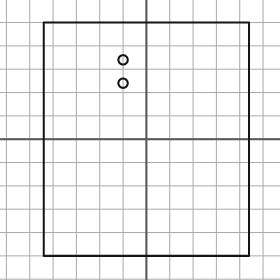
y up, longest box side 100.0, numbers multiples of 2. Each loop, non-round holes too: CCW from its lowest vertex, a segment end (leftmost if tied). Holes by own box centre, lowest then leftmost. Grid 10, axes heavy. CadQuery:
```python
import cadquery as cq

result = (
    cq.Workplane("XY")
    .moveTo(-44.0, -50.0)
    .lineTo(44.0, -50.0)
    .lineTo(44.0, 50.0)
    .lineTo(-44.0, 50.0)
    .close()
    .moveTo(-10.0, 24.0)
    .circle(2.0)
    .moveTo(-10.0, 34.0)
    .circle(2.0)
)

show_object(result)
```